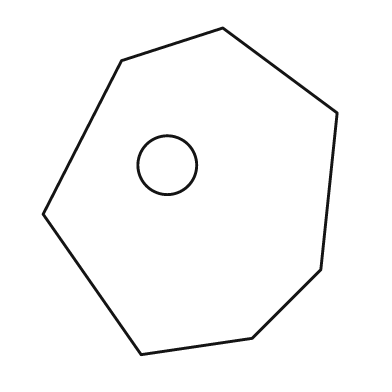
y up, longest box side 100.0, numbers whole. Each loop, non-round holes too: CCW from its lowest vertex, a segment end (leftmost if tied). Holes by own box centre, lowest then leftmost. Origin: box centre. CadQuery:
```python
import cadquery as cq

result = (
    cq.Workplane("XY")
    .moveTo(-15.0, -50.0)
    .lineTo(19.0, -45.0)
    .lineTo(40.0, -24.0)
    .lineTo(45.0, 24.0)
    .lineTo(10.0, 50.0)
    .lineTo(-21.0, 40.0)
    .lineTo(-45.0, -7.0)
    .close()
    .moveTo(-7.0, 8.0)
    .circle(9.0)
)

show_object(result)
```